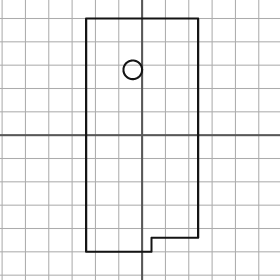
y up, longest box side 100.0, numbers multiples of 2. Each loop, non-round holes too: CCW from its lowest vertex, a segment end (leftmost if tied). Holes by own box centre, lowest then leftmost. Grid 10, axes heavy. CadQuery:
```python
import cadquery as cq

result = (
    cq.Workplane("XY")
    .moveTo(-24.0, -50.0)
    .lineTo(4.0, -50.0)
    .lineTo(4.0, -44.0)
    .lineTo(24.0, -44.0)
    .lineTo(24.0, 50.0)
    .lineTo(-24.0, 50.0)
    .close()
    .moveTo(-4.0, 28.0)
    .circle(4.0)
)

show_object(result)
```